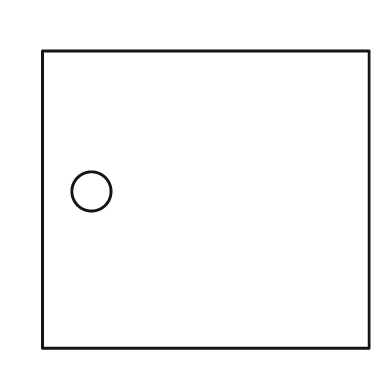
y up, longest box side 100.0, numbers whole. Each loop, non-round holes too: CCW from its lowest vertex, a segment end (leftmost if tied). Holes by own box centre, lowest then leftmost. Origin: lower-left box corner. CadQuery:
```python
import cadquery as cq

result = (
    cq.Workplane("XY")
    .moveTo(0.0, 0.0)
    .lineTo(100.0, 0.0)
    .lineTo(100.0, 91.0)
    .lineTo(0.0, 91.0)
    .close()
    .moveTo(15.0, 48.0)
    .circle(6.0)
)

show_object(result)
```